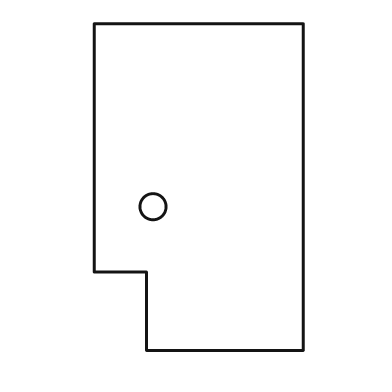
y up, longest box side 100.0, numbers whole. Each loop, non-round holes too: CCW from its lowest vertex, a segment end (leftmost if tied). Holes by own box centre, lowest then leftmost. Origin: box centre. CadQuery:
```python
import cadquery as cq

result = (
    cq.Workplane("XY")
    .moveTo(-16.0, -50.0)
    .lineTo(32.0, -50.0)
    .lineTo(32.0, 50.0)
    .lineTo(-32.0, 50.0)
    .lineTo(-32.0, -26.0)
    .lineTo(-16.0, -26.0)
    .close()
    .moveTo(-14.0, -6.0)
    .circle(4.0)
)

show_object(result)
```